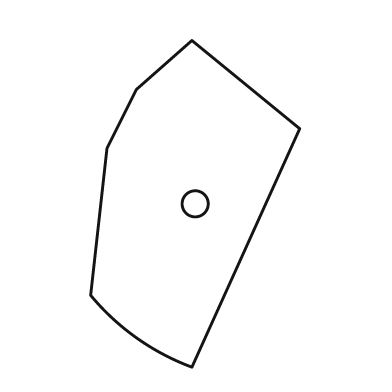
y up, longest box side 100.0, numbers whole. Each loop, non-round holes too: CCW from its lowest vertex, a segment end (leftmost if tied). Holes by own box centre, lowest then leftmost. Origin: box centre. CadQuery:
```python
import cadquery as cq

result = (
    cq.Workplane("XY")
    .moveTo(-1.0, -50.0)
    .lineTo(32.0, 23.0)
    .lineTo(-1.0, 50.0)
    .lineTo(-18.0, 35.0)
    .lineTo(-27.0, 17.0)
    .lineTo(-32.0, -28.0)
    .threePointArc((-18.0, -41.0), (-1.0, -50.0))
    .close()
    .moveTo(0.0, 0.0)
    .circle(4.0)
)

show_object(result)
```